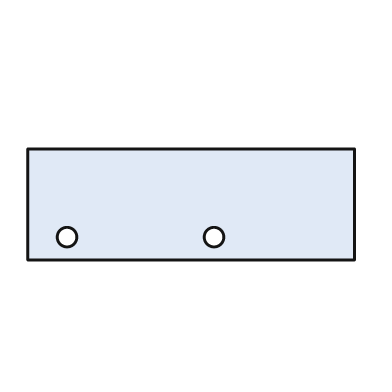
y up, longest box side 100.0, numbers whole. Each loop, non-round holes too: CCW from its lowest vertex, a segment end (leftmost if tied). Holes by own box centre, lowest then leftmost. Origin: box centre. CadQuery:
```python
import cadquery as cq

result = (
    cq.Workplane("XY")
    .moveTo(-50.0, -17.0)
    .lineTo(50.0, -17.0)
    .lineTo(50.0, 17.0)
    .lineTo(-50.0, 17.0)
    .close()
    .moveTo(-38.0, -10.0)
    .circle(3.0)
    .moveTo(7.0, -10.0)
    .circle(3.0)
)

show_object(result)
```